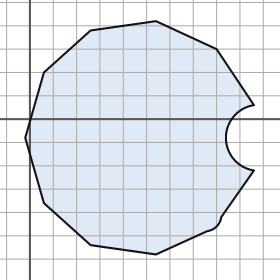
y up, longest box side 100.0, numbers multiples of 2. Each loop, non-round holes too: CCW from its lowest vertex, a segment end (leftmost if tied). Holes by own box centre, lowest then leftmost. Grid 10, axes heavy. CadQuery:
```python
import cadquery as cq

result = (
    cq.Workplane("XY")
    .moveTo(54.0, -58.0)
    .lineTo(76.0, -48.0)
    .threePointArc((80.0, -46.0), (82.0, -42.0))
    .lineTo(96.0, -22.0)
    .threePointArc((84.0, -8.0), (96.0, 6.0))
    .lineTo(80.0, 30.0)
    .lineTo(54.0, 42.0)
    .lineTo(26.0, 38.0)
    .lineTo(6.0, 20.0)
    .lineTo(-2.0, -8.0)
    .lineTo(6.0, -36.0)
    .lineTo(26.0, -54.0)
    .close()
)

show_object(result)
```